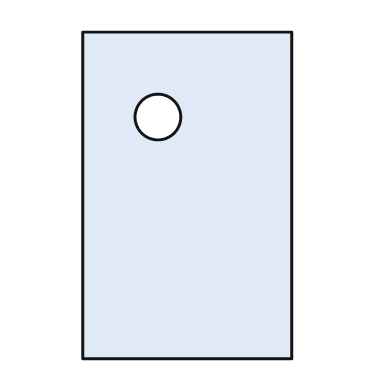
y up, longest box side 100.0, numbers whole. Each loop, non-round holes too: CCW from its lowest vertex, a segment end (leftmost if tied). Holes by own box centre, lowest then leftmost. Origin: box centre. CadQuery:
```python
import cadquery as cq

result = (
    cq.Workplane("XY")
    .moveTo(-32.0, -50.0)
    .lineTo(32.0, -50.0)
    .lineTo(32.0, 50.0)
    .lineTo(-32.0, 50.0)
    .close()
    .moveTo(-9.0, 24.0)
    .circle(7.0)
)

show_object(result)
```